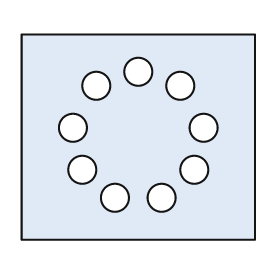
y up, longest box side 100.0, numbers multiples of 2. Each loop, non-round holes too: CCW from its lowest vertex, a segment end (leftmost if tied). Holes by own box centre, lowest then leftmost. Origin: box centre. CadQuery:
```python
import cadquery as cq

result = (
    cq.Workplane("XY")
    .moveTo(-50.0, -44.0)
    .lineTo(50.0, -44.0)
    .lineTo(50.0, 44.0)
    .lineTo(-50.0, 44.0)
    .close()
    .moveTo(-10.0, -26.0)
    .circle(6.0)
    .moveTo(10.0, -26.0)
    .circle(6.0)
    .moveTo(-24.0, -14.0)
    .circle(6.0)
    .moveTo(24.0, -14.0)
    .circle(6.0)
    .moveTo(-28.0, 4.0)
    .circle(6.0)
    .moveTo(28.0, 4.0)
    .circle(6.0)
    .moveTo(-18.0, 22.0)
    .circle(6.0)
    .moveTo(18.0, 22.0)
    .circle(6.0)
    .moveTo(0.0, 28.0)
    .circle(6.0)
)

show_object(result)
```